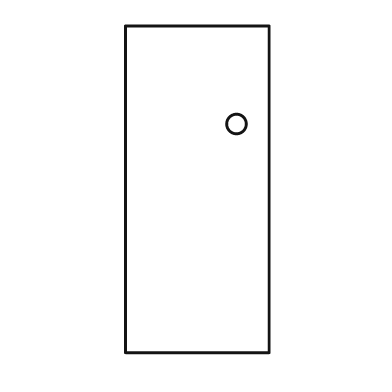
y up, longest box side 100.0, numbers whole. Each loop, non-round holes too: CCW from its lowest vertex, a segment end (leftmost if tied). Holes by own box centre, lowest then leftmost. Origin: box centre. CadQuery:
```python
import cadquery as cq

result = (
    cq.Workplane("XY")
    .moveTo(-22.0, -50.0)
    .lineTo(22.0, -50.0)
    .lineTo(22.0, 50.0)
    .lineTo(-22.0, 50.0)
    .close()
    .moveTo(12.0, 20.0)
    .circle(3.0)
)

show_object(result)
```